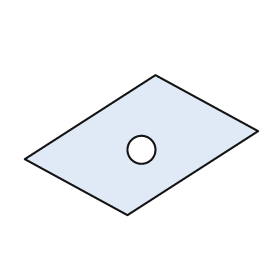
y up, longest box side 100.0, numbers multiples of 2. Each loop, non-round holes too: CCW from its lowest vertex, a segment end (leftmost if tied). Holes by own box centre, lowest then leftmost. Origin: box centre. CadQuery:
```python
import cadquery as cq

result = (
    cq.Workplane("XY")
    .moveTo(-6.0, -30.0)
    .lineTo(50.0, 6.0)
    .lineTo(6.0, 30.0)
    .lineTo(-50.0, -6.0)
    .close()
    .moveTo(0.0, -2.0)
    .circle(6.0)
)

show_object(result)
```